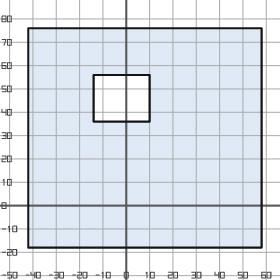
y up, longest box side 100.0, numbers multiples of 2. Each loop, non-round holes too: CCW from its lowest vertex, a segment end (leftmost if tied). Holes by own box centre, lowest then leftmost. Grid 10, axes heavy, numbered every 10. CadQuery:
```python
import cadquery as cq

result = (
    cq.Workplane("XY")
    .moveTo(-42.0, -18.0)
    .lineTo(58.0, -18.0)
    .lineTo(58.0, 76.0)
    .lineTo(-42.0, 76.0)
    .close()
    .moveTo(-14.0, 36.0)
    .lineTo(10.0, 36.0)
    .lineTo(10.0, 56.0)
    .lineTo(-14.0, 56.0)
    .close()
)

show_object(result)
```